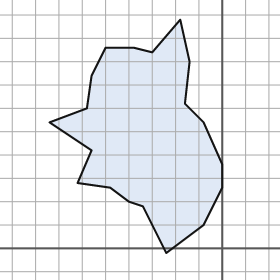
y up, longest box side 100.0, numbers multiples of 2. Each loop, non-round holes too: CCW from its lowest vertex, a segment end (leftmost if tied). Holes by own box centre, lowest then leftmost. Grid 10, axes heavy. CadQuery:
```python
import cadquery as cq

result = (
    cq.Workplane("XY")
    .moveTo(-24.0, -2.0)
    .lineTo(-8.0, 10.0)
    .lineTo(0.0, 26.0)
    .lineTo(0.0, 36.0)
    .lineTo(-8.0, 54.0)
    .lineTo(-16.0, 62.0)
    .lineTo(-14.0, 80.0)
    .lineTo(-18.0, 98.0)
    .lineTo(-30.0, 84.0)
    .lineTo(-38.0, 86.0)
    .lineTo(-50.0, 86.0)
    .lineTo(-56.0, 74.0)
    .lineTo(-58.0, 60.0)
    .lineTo(-74.0, 54.0)
    .lineTo(-56.0, 42.0)
    .lineTo(-62.0, 28.0)
    .lineTo(-48.0, 26.0)
    .lineTo(-40.0, 20.0)
    .lineTo(-34.0, 18.0)
    .close()
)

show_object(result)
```